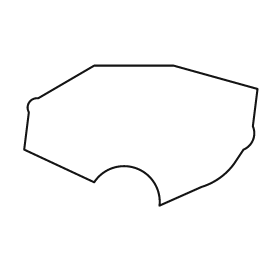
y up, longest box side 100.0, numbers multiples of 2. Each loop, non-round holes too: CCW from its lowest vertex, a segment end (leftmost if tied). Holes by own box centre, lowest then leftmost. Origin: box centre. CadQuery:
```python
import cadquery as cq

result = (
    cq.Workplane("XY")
    .moveTo(8.0, -30.0)
    .lineTo(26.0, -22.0)
    .threePointArc((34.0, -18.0), (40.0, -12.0))
    .lineTo(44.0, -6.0)
    .threePointArc((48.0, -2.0), (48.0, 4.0))
    .lineTo(50.0, 20.0)
    .lineTo(14.0, 30.0)
    .lineTo(-20.0, 30.0)
    .lineTo(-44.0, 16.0)
    .threePointArc((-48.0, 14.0), (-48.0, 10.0))
    .lineTo(-50.0, -6.0)
    .lineTo(-20.0, -20.0)
    .threePointArc((-2.0, -14.0), (8.0, -30.0))
    .close()
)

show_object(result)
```